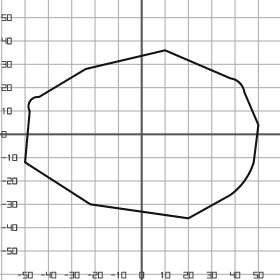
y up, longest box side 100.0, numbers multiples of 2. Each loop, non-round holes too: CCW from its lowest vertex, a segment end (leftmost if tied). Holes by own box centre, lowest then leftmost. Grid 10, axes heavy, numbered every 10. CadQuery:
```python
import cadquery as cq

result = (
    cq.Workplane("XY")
    .moveTo(20.0, -36.0)
    .lineTo(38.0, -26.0)
    .threePointArc((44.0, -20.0), (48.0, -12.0))
    .lineTo(50.0, 4.0)
    .lineTo(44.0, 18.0)
    .threePointArc((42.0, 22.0), (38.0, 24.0))
    .lineTo(10.0, 36.0)
    .lineTo(-24.0, 28.0)
    .lineTo(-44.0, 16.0)
    .threePointArc((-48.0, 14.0), (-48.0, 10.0))
    .lineTo(-50.0, -12.0)
    .lineTo(-22.0, -30.0)
    .close()
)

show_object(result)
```